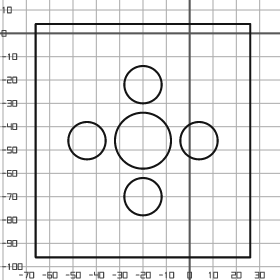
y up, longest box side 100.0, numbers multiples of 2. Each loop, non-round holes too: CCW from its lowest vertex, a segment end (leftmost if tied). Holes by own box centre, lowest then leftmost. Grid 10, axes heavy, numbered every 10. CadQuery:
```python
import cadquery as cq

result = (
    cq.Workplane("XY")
    .moveTo(-66.0, -96.0)
    .lineTo(26.0, -96.0)
    .lineTo(26.0, 4.0)
    .lineTo(-66.0, 4.0)
    .close()
    .moveTo(-20.0, -70.0)
    .circle(8.0)
    .moveTo(-44.0, -46.0)
    .circle(8.0)
    .moveTo(-20.0, -46.0)
    .circle(12.0)
    .moveTo(4.0, -46.0)
    .circle(8.0)
    .moveTo(-20.0, -22.0)
    .circle(8.0)
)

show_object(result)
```